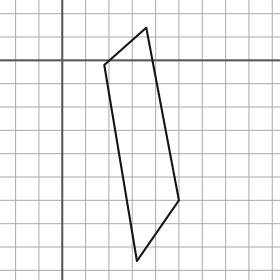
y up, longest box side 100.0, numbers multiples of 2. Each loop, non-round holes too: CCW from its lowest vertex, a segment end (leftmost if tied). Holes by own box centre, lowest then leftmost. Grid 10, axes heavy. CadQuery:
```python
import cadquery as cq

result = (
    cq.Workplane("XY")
    .moveTo(32.0, -86.0)
    .lineTo(50.0, -60.0)
    .lineTo(36.0, 14.0)
    .lineTo(18.0, -2.0)
    .close()
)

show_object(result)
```